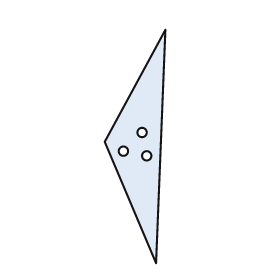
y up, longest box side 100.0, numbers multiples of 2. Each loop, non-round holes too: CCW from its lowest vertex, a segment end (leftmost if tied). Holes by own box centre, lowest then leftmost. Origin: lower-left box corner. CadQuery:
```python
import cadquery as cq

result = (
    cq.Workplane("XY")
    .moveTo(22.0, 0.0)
    .lineTo(26.0, 100.0)
    .lineTo(0.0, 52.0)
    .close()
    .moveTo(18.0, 46.0)
    .circle(2.0)
    .moveTo(8.0, 48.0)
    .circle(2.0)
    .moveTo(16.0, 56.0)
    .circle(2.0)
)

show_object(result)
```